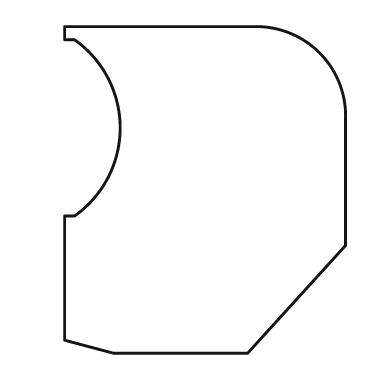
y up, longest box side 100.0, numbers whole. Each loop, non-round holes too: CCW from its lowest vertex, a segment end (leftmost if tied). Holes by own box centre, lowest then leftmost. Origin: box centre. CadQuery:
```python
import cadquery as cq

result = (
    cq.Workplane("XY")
    .moveTo(-28.0, -50.0)
    .lineTo(13.0, -50.0)
    .lineTo(43.0, -17.0)
    .lineTo(43.0, 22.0)
    .threePointArc((35.0, 42.0), (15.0, 50.0))
    .lineTo(-43.0, 50.0)
    .lineTo(-43.0, 46.0)
    .lineTo(-40.0, 46.0)
    .threePointArc((-26.0, 19.0), (-40.0, -8.0))
    .lineTo(-43.0, -8.0)
    .lineTo(-43.0, -46.0)
    .close()
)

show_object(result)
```